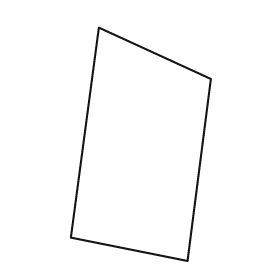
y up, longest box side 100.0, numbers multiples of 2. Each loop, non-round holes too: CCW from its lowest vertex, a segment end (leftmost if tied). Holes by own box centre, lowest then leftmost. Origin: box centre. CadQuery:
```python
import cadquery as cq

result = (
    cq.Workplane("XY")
    .moveTo(20.0, -50.0)
    .lineTo(30.0, 28.0)
    .lineTo(-18.0, 50.0)
    .lineTo(-30.0, -40.0)
    .close()
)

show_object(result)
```